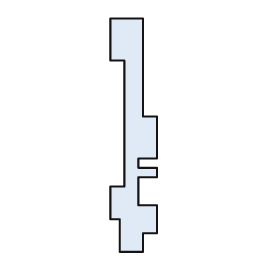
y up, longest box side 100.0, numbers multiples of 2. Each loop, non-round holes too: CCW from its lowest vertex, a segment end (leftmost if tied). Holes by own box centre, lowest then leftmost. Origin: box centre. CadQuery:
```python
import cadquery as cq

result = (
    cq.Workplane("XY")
    .moveTo(-6.0, -50.0)
    .lineTo(4.0, -50.0)
    .lineTo(4.0, -42.0)
    .lineTo(10.0, -42.0)
    .lineTo(10.0, -30.0)
    .lineTo(2.0, -30.0)
    .lineTo(2.0, -18.0)
    .lineTo(10.0, -18.0)
    .lineTo(10.0, -14.0)
    .lineTo(2.0, -14.0)
    .lineTo(2.0, -10.0)
    .lineTo(10.0, -10.0)
    .lineTo(10.0, 8.0)
    .lineTo(4.0, 8.0)
    .lineTo(4.0, 50.0)
    .lineTo(-10.0, 50.0)
    .lineTo(-10.0, 32.0)
    .lineTo(-4.0, 32.0)
    .lineTo(-4.0, -22.0)
    .lineTo(-10.0, -22.0)
    .lineTo(-10.0, -36.0)
    .lineTo(-6.0, -36.0)
    .close()
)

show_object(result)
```